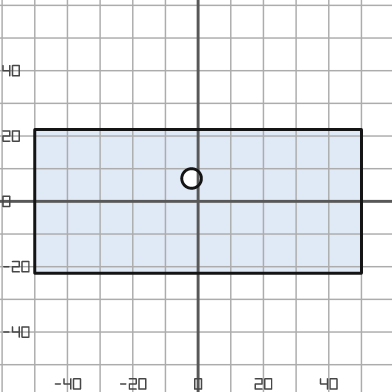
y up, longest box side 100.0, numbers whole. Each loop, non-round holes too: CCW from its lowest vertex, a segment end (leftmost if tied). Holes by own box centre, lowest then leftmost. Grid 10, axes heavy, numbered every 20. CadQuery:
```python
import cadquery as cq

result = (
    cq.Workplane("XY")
    .moveTo(-50.0, -22.0)
    .lineTo(50.0, -22.0)
    .lineTo(50.0, 22.0)
    .lineTo(-50.0, 22.0)
    .close()
    .moveTo(-2.0, 7.0)
    .circle(3.0)
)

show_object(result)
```